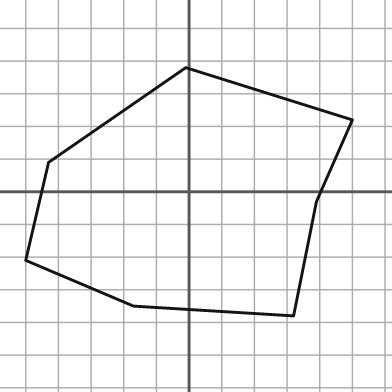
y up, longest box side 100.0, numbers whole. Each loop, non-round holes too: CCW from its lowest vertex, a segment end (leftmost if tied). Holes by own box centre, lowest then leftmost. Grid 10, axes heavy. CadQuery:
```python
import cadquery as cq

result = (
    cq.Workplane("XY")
    .moveTo(32.0, -38.0)
    .lineTo(39.0, -3.0)
    .lineTo(50.0, 22.0)
    .lineTo(-1.0, 38.0)
    .lineTo(-43.0, 9.0)
    .lineTo(-50.0, -21.0)
    .lineTo(-17.0, -35.0)
    .close()
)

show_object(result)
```